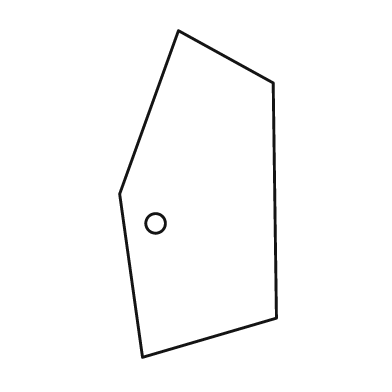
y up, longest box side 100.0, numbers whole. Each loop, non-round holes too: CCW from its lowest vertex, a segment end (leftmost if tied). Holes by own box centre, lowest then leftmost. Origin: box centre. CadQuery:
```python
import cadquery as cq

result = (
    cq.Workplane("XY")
    .moveTo(-17.0, -50.0)
    .lineTo(24.0, -38.0)
    .lineTo(23.0, 34.0)
    .lineTo(-6.0, 50.0)
    .lineTo(-24.0, 0.0)
    .close()
    .moveTo(-13.0, -9.0)
    .circle(3.0)
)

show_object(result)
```